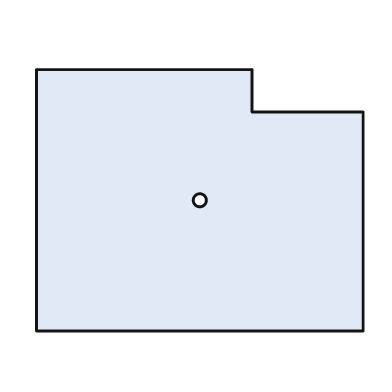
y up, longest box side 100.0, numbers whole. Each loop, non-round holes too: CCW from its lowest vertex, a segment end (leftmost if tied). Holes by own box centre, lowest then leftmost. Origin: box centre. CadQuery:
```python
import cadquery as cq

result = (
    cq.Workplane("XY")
    .moveTo(-50.0, -40.0)
    .lineTo(50.0, -40.0)
    .lineTo(50.0, 27.0)
    .lineTo(16.0, 27.0)
    .lineTo(16.0, 40.0)
    .lineTo(-50.0, 40.0)
    .close()
    .moveTo(0.0, 0.0)
    .circle(2.0)
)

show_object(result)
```